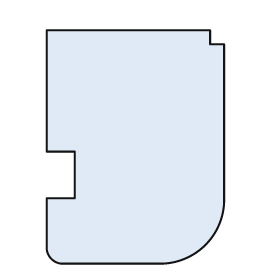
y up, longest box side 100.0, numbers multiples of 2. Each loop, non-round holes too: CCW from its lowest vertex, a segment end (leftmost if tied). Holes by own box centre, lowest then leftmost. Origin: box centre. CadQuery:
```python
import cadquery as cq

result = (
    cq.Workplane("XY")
    .moveTo(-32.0, -50.0)
    .lineTo(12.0, -50.0)
    .threePointArc((30.0, -42.0), (38.0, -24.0))
    .lineTo(38.0, 44.0)
    .lineTo(32.0, 44.0)
    .lineTo(32.0, 50.0)
    .lineTo(-38.0, 50.0)
    .lineTo(-38.0, -2.0)
    .lineTo(-26.0, -2.0)
    .lineTo(-26.0, -22.0)
    .lineTo(-38.0, -22.0)
    .lineTo(-38.0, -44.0)
    .threePointArc((-36.0, -48.0), (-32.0, -50.0))
    .close()
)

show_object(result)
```